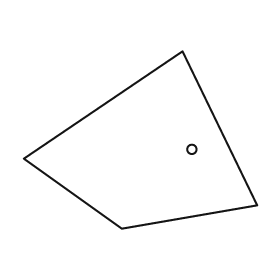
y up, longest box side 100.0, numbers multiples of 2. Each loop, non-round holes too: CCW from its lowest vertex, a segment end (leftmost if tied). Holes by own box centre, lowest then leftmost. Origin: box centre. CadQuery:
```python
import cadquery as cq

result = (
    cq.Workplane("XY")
    .moveTo(-8.0, -38.0)
    .lineTo(50.0, -28.0)
    .lineTo(18.0, 38.0)
    .lineTo(-50.0, -8.0)
    .close()
    .moveTo(22.0, -4.0)
    .circle(2.0)
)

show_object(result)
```